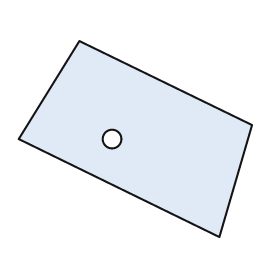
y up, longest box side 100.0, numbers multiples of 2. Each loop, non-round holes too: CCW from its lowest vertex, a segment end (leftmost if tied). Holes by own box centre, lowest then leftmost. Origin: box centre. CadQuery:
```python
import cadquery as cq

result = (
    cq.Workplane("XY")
    .moveTo(36.0, -42.0)
    .lineTo(50.0, 6.0)
    .lineTo(-24.0, 42.0)
    .lineTo(-50.0, 0.0)
    .close()
    .moveTo(-10.0, 0.0)
    .circle(4.0)
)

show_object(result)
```